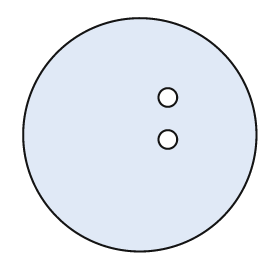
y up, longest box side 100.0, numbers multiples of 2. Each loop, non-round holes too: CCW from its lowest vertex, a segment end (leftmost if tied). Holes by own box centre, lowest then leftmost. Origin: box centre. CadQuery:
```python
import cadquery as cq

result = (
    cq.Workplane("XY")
    .moveTo(0.0, 0.0)
    .circle(50.0)
    .moveTo(12.0, -2.0)
    .circle(4.0)
    .moveTo(12.0, 16.0)
    .circle(4.0)
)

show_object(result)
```